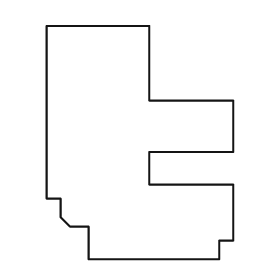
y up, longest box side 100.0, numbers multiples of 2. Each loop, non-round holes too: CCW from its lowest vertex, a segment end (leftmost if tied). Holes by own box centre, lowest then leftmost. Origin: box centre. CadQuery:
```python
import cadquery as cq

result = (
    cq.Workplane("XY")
    .moveTo(-22.0, -50.0)
    .lineTo(34.0, -50.0)
    .lineTo(34.0, -42.0)
    .lineTo(40.0, -42.0)
    .lineTo(40.0, -18.0)
    .lineTo(4.0, -18.0)
    .lineTo(4.0, -4.0)
    .lineTo(40.0, -4.0)
    .lineTo(40.0, 18.0)
    .lineTo(4.0, 18.0)
    .lineTo(4.0, 50.0)
    .lineTo(-40.0, 50.0)
    .lineTo(-40.0, -24.0)
    .lineTo(-34.0, -24.0)
    .lineTo(-34.0, -32.0)
    .lineTo(-30.0, -36.0)
    .lineTo(-22.0, -36.0)
    .close()
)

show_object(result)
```